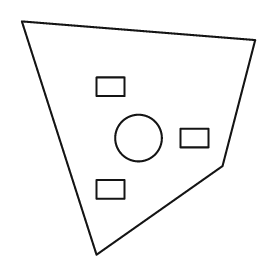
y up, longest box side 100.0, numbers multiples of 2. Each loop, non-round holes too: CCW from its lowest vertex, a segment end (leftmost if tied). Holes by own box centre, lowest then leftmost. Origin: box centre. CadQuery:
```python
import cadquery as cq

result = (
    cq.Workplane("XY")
    .moveTo(-18.0, -50.0)
    .lineTo(36.0, -12.0)
    .lineTo(50.0, 42.0)
    .lineTo(-50.0, 50.0)
    .close()
    .moveTo(-18.0, -26.0)
    .lineTo(-6.0, -26.0)
    .lineTo(-6.0, -18.0)
    .lineTo(-18.0, -18.0)
    .close()
    .moveTo(0.0, 0.0)
    .circle(10.0)
    .moveTo(18.0, -4.0)
    .lineTo(30.0, -4.0)
    .lineTo(30.0, 4.0)
    .lineTo(18.0, 4.0)
    .close()
    .moveTo(-18.0, 18.0)
    .lineTo(-6.0, 18.0)
    .lineTo(-6.0, 26.0)
    .lineTo(-18.0, 26.0)
    .close()
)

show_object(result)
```